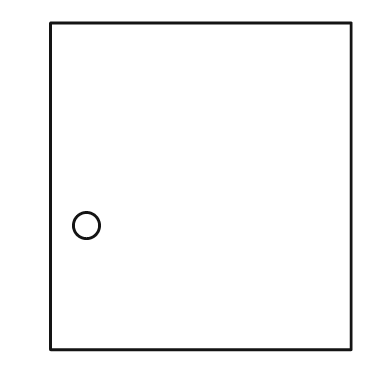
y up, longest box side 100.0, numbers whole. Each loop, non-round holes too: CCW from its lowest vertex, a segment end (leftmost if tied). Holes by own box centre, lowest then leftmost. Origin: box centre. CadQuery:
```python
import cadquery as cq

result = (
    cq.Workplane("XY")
    .moveTo(-46.0, -50.0)
    .lineTo(46.0, -50.0)
    .lineTo(46.0, 50.0)
    .lineTo(-46.0, 50.0)
    .close()
    .moveTo(-35.0, -12.0)
    .circle(4.0)
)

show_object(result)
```